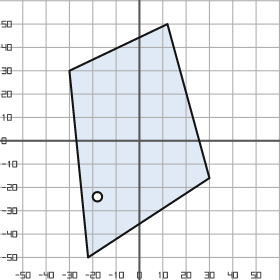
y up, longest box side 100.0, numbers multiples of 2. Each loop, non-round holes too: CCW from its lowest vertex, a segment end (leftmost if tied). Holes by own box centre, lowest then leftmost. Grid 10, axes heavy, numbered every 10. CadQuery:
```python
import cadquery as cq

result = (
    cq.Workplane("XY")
    .moveTo(-22.0, -50.0)
    .lineTo(30.0, -16.0)
    .lineTo(12.0, 50.0)
    .lineTo(-30.0, 30.0)
    .close()
    .moveTo(-18.0, -24.0)
    .circle(2.0)
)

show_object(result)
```